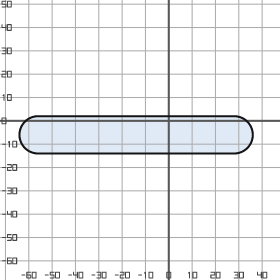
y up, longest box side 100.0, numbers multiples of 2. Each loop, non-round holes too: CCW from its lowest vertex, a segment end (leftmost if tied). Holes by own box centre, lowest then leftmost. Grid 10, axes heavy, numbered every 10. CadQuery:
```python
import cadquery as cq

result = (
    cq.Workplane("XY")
    .moveTo(-56.0, -14.0)
    .lineTo(28.0, -14.0)
    .threePointArc((36.0, -6.0), (28.0, 2.0))
    .lineTo(-56.0, 2.0)
    .threePointArc((-64.0, -6.0), (-56.0, -14.0))
    .close()
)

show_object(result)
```